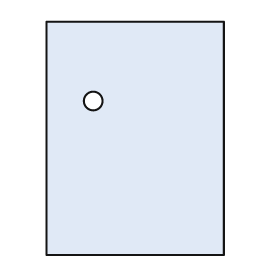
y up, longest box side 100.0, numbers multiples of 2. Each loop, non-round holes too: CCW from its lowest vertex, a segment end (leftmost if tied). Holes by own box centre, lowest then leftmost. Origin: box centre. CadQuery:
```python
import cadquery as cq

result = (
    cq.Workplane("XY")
    .moveTo(-38.0, -50.0)
    .lineTo(38.0, -50.0)
    .lineTo(38.0, 50.0)
    .lineTo(-38.0, 50.0)
    .close()
    .moveTo(-18.0, 16.0)
    .circle(4.0)
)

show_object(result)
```